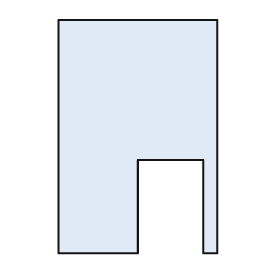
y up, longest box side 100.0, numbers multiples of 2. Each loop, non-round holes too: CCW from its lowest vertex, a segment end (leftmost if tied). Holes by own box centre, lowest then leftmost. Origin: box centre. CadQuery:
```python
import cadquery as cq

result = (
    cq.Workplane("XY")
    .moveTo(-34.0, -50.0)
    .lineTo(0.0, -50.0)
    .lineTo(0.0, -10.0)
    .lineTo(28.0, -10.0)
    .lineTo(28.0, -50.0)
    .lineTo(34.0, -50.0)
    .lineTo(34.0, 50.0)
    .lineTo(-34.0, 50.0)
    .close()
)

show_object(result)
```